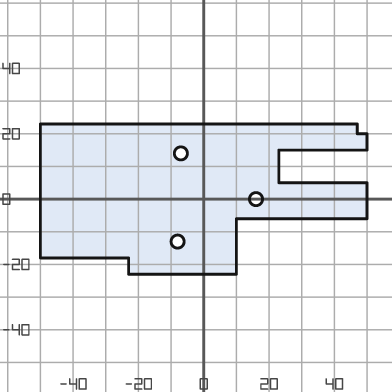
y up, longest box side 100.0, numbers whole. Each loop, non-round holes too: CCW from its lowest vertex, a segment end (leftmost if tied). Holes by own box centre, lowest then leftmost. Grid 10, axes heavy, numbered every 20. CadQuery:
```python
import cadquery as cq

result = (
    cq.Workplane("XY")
    .moveTo(-23.0, -23.0)
    .lineTo(10.0, -23.0)
    .lineTo(10.0, -6.0)
    .lineTo(50.0, -6.0)
    .lineTo(50.0, 5.0)
    .lineTo(23.0, 5.0)
    .lineTo(23.0, 15.0)
    .lineTo(50.0, 15.0)
    .lineTo(50.0, 20.0)
    .lineTo(47.0, 20.0)
    .lineTo(47.0, 23.0)
    .lineTo(-50.0, 23.0)
    .lineTo(-50.0, -18.0)
    .lineTo(-23.0, -18.0)
    .close()
    .moveTo(-8.0, -13.0)
    .circle(2.0)
    .moveTo(16.0, 0.0)
    .circle(2.0)
    .moveTo(-7.0, 14.0)
    .circle(2.0)
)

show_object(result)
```